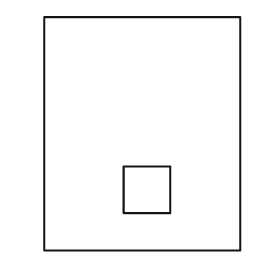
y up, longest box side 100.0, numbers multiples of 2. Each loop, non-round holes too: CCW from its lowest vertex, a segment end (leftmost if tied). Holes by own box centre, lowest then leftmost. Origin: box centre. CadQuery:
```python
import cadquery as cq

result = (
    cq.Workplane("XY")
    .moveTo(-42.0, -50.0)
    .lineTo(42.0, -50.0)
    .lineTo(42.0, 50.0)
    .lineTo(-42.0, 50.0)
    .close()
    .moveTo(-8.0, -34.0)
    .lineTo(12.0, -34.0)
    .lineTo(12.0, -14.0)
    .lineTo(-8.0, -14.0)
    .close()
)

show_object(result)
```